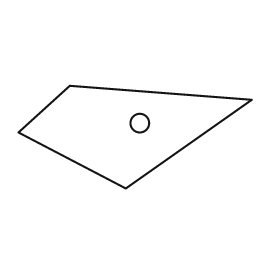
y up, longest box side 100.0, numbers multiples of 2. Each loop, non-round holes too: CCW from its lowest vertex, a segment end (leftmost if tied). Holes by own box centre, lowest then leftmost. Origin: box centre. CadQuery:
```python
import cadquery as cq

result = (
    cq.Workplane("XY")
    .moveTo(-4.0, -22.0)
    .lineTo(50.0, 16.0)
    .lineTo(-28.0, 22.0)
    .lineTo(-50.0, 2.0)
    .close()
    .moveTo(2.0, 6.0)
    .circle(4.0)
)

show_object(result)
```